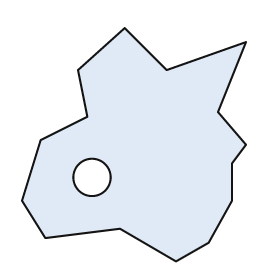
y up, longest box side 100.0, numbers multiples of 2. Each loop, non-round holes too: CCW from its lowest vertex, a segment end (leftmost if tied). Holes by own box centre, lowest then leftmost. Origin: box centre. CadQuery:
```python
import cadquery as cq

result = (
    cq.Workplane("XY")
    .moveTo(18.0, -50.0)
    .lineTo(32.0, -42.0)
    .lineTo(42.0, -24.0)
    .lineTo(42.0, -8.0)
    .lineTo(48.0, 0.0)
    .lineTo(36.0, 14.0)
    .lineTo(48.0, 44.0)
    .lineTo(14.0, 32.0)
    .lineTo(-4.0, 50.0)
    .lineTo(-24.0, 32.0)
    .lineTo(-20.0, 12.0)
    .lineTo(-40.0, 2.0)
    .lineTo(-48.0, -24.0)
    .lineTo(-38.0, -40.0)
    .lineTo(-6.0, -36.0)
    .close()
    .moveTo(-18.0, -14.0)
    .circle(8.0)
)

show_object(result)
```